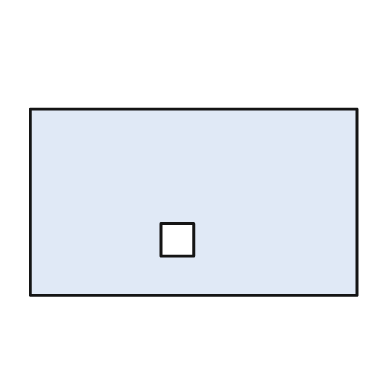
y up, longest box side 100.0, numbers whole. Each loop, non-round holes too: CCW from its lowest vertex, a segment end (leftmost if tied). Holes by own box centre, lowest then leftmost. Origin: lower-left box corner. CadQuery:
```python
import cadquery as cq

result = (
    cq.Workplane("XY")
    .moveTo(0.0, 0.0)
    .lineTo(100.0, 0.0)
    .lineTo(100.0, 57.0)
    .lineTo(0.0, 57.0)
    .close()
    .moveTo(40.0, 12.0)
    .lineTo(50.0, 12.0)
    .lineTo(50.0, 22.0)
    .lineTo(40.0, 22.0)
    .close()
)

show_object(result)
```